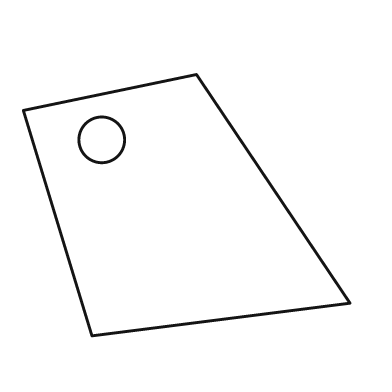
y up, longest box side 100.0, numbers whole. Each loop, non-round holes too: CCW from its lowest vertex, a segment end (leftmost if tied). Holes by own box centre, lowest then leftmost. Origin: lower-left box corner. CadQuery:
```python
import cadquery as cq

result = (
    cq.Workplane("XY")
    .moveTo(21.0, 0.0)
    .lineTo(100.0, 10.0)
    .lineTo(53.0, 80.0)
    .lineTo(0.0, 69.0)
    .close()
    .moveTo(24.0, 60.0)
    .circle(7.0)
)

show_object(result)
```